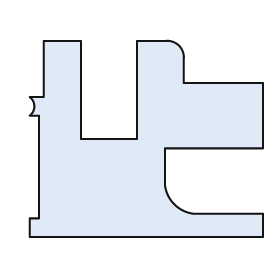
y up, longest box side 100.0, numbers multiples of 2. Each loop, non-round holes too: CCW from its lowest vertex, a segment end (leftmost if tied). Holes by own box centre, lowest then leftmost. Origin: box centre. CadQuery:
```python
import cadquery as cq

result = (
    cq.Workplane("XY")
    .moveTo(-50.0, -42.0)
    .lineTo(50.0, -42.0)
    .lineTo(50.0, -32.0)
    .lineTo(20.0, -32.0)
    .threePointArc((12.0, -28.0), (8.0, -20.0))
    .lineTo(8.0, -4.0)
    .lineTo(50.0, -4.0)
    .lineTo(50.0, 24.0)
    .lineTo(16.0, 24.0)
    .lineTo(16.0, 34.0)
    .threePointArc((14.0, 40.0), (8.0, 42.0))
    .lineTo(-4.0, 42.0)
    .lineTo(-4.0, 0.0)
    .lineTo(-28.0, 0.0)
    .lineTo(-28.0, 42.0)
    .lineTo(-44.0, 42.0)
    .lineTo(-44.0, 18.0)
    .lineTo(-50.0, 18.0)
    .threePointArc((-48.0, 14.0), (-50.0, 10.0))
    .lineTo(-46.0, 10.0)
    .lineTo(-46.0, -34.0)
    .lineTo(-50.0, -34.0)
    .close()
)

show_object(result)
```